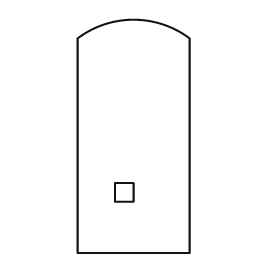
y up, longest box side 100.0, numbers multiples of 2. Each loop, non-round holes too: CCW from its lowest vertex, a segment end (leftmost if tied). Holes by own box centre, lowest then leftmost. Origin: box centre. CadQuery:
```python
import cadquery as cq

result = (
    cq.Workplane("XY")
    .moveTo(-24.0, -50.0)
    .lineTo(24.0, -50.0)
    .lineTo(24.0, 42.0)
    .threePointArc((0.0, 50.0), (-24.0, 42.0))
    .close()
    .moveTo(-8.0, -28.0)
    .lineTo(0.0, -28.0)
    .lineTo(0.0, -20.0)
    .lineTo(-8.0, -20.0)
    .close()
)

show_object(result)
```